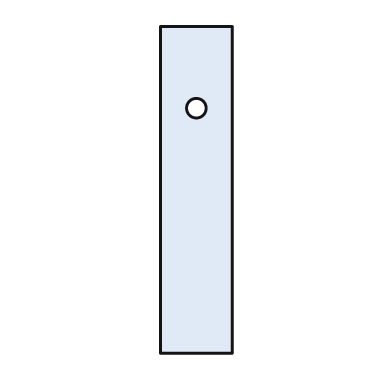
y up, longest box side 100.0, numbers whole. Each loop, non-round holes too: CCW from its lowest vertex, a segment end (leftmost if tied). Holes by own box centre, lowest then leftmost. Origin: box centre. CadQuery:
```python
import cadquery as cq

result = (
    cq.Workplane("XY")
    .moveTo(-11.0, -50.0)
    .lineTo(11.0, -50.0)
    .lineTo(11.0, 50.0)
    .lineTo(-11.0, 50.0)
    .close()
    .moveTo(0.0, 25.0)
    .circle(3.0)
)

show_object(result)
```